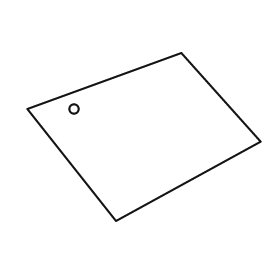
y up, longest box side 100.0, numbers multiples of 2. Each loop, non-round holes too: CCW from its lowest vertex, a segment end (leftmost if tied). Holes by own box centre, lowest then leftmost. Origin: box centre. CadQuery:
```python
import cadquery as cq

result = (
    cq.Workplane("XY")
    .moveTo(-12.0, -36.0)
    .lineTo(50.0, -2.0)
    .lineTo(16.0, 36.0)
    .lineTo(-50.0, 12.0)
    .close()
    .moveTo(-30.0, 12.0)
    .circle(2.0)
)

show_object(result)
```